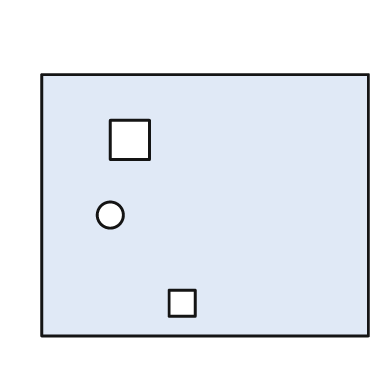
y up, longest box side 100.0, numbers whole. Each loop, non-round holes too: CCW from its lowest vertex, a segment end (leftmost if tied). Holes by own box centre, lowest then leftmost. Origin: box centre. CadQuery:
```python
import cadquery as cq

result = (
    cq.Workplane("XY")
    .moveTo(-50.0, -40.0)
    .lineTo(50.0, -40.0)
    .lineTo(50.0, 40.0)
    .lineTo(-50.0, 40.0)
    .close()
    .moveTo(-11.0, -34.0)
    .lineTo(-3.0, -34.0)
    .lineTo(-3.0, -26.0)
    .lineTo(-11.0, -26.0)
    .close()
    .moveTo(-29.0, -3.0)
    .circle(4.0)
    .moveTo(-29.0, 14.0)
    .lineTo(-17.0, 14.0)
    .lineTo(-17.0, 26.0)
    .lineTo(-29.0, 26.0)
    .close()
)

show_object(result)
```